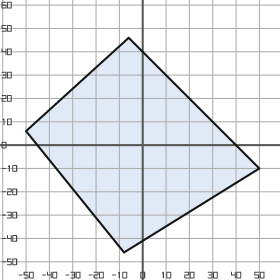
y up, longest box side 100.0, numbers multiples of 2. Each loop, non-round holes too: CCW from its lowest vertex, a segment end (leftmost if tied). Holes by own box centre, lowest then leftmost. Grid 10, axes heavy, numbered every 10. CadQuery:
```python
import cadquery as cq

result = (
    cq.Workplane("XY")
    .moveTo(-8.0, -46.0)
    .lineTo(50.0, -10.0)
    .lineTo(-6.0, 46.0)
    .lineTo(-50.0, 6.0)
    .close()
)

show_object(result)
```